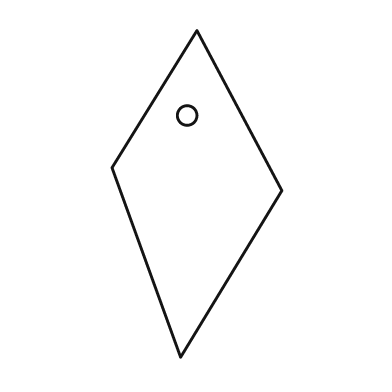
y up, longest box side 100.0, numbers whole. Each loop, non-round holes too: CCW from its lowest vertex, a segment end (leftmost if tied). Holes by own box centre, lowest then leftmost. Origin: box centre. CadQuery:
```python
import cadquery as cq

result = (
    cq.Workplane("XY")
    .moveTo(-5.0, -50.0)
    .lineTo(26.0, 1.0)
    .lineTo(0.0, 50.0)
    .lineTo(-26.0, 8.0)
    .close()
    .moveTo(-3.0, 24.0)
    .circle(3.0)
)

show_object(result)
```